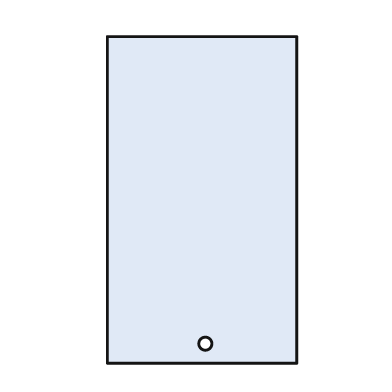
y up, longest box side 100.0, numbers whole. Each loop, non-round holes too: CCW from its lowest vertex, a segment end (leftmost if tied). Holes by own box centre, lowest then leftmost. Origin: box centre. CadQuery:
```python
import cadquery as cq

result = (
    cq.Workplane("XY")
    .moveTo(-29.0, -50.0)
    .lineTo(29.0, -50.0)
    .lineTo(29.0, 50.0)
    .lineTo(-29.0, 50.0)
    .close()
    .moveTo(1.0, -44.0)
    .circle(2.0)
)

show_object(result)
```